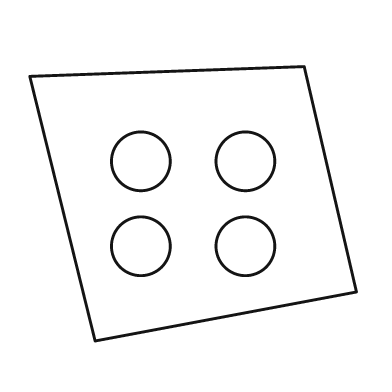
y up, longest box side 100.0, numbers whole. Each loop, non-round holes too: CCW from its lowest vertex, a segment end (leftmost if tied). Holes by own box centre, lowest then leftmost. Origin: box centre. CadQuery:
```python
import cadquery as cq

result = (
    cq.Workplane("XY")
    .moveTo(-30.0, -42.0)
    .lineTo(50.0, -27.0)
    .lineTo(34.0, 42.0)
    .lineTo(-50.0, 39.0)
    .close()
    .moveTo(-16.0, -13.0)
    .circle(9.0)
    .moveTo(16.0, -13.0)
    .circle(9.0)
    .moveTo(-16.0, 13.0)
    .circle(9.0)
    .moveTo(16.0, 13.0)
    .circle(9.0)
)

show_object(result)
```